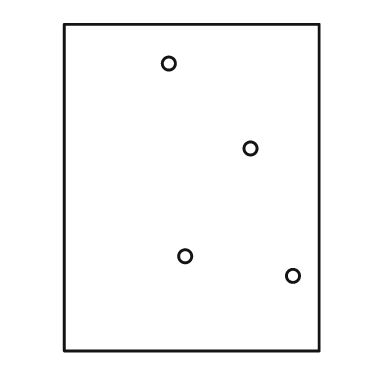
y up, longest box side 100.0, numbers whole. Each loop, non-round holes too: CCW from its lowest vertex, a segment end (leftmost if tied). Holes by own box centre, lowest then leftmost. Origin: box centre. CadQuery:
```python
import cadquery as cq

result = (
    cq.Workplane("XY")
    .moveTo(-39.0, -50.0)
    .lineTo(39.0, -50.0)
    .lineTo(39.0, 50.0)
    .lineTo(-39.0, 50.0)
    .close()
    .moveTo(31.0, -27.0)
    .circle(2.0)
    .moveTo(-2.0, -21.0)
    .circle(2.0)
    .moveTo(18.0, 12.0)
    .circle(2.0)
    .moveTo(-7.0, 38.0)
    .circle(2.0)
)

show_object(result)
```